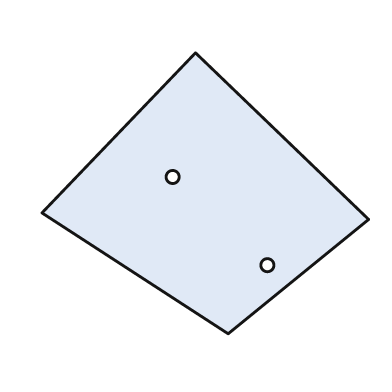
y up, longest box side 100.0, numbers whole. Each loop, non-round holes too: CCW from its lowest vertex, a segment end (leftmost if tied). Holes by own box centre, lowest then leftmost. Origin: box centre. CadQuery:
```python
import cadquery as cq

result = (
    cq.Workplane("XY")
    .moveTo(7.0, -43.0)
    .lineTo(50.0, -8.0)
    .lineTo(-3.0, 43.0)
    .lineTo(-50.0, -6.0)
    .close()
    .moveTo(19.0, -22.0)
    .circle(2.0)
    .moveTo(-10.0, 5.0)
    .circle(2.0)
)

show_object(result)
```